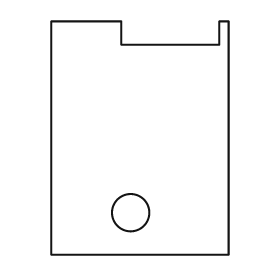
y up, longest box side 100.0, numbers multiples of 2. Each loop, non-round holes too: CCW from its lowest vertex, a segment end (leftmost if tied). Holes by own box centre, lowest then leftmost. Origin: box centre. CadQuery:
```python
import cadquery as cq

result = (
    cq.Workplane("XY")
    .moveTo(-38.0, -50.0)
    .lineTo(38.0, -50.0)
    .lineTo(38.0, 50.0)
    .lineTo(34.0, 50.0)
    .lineTo(34.0, 40.0)
    .lineTo(-8.0, 40.0)
    .lineTo(-8.0, 50.0)
    .lineTo(-38.0, 50.0)
    .close()
    .moveTo(-4.0, -32.0)
    .circle(8.0)
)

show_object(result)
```